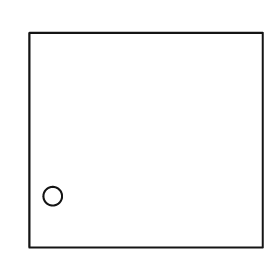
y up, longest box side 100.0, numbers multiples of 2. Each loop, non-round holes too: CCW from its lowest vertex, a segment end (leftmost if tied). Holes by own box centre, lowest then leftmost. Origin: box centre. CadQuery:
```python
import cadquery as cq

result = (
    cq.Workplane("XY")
    .moveTo(-50.0, -46.0)
    .lineTo(50.0, -46.0)
    .lineTo(50.0, 46.0)
    .lineTo(-50.0, 46.0)
    .close()
    .moveTo(-40.0, -24.0)
    .circle(4.0)
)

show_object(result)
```